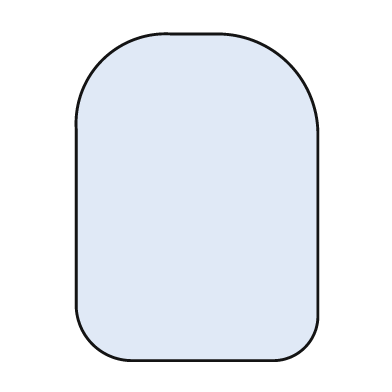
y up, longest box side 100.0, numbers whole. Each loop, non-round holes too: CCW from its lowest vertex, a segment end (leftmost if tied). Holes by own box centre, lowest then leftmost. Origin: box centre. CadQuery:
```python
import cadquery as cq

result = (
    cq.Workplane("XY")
    .moveTo(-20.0, -50.0)
    .lineTo(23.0, -50.0)
    .threePointArc((33.0, -46.0), (37.0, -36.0))
    .lineTo(37.0, 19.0)
    .threePointArc((28.0, 41.0), (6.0, 50.0))
    .lineTo(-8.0, 50.0)
    .threePointArc((-29.0, 42.0), (-37.0, 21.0))
    .lineTo(-37.0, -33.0)
    .threePointArc((-32.0, -45.0), (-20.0, -50.0))
    .close()
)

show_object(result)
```